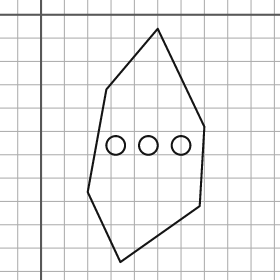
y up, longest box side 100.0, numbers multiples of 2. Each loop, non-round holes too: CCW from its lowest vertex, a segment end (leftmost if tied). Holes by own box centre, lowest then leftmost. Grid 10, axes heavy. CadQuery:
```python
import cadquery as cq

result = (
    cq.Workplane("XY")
    .moveTo(34.0, -106.0)
    .lineTo(68.0, -82.0)
    .lineTo(70.0, -48.0)
    .lineTo(50.0, -6.0)
    .lineTo(28.0, -32.0)
    .lineTo(20.0, -76.0)
    .close()
    .moveTo(32.0, -56.0)
    .circle(4.0)
    .moveTo(46.0, -56.0)
    .circle(4.0)
    .moveTo(60.0, -56.0)
    .circle(4.0)
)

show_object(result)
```